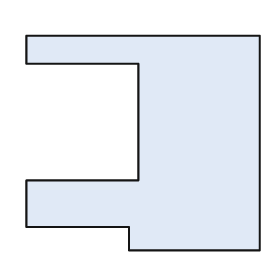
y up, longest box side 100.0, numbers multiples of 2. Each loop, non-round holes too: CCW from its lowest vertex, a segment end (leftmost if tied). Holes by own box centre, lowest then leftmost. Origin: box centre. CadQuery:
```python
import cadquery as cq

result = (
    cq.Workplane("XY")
    .moveTo(-6.0, -46.0)
    .lineTo(50.0, -46.0)
    .lineTo(50.0, 46.0)
    .lineTo(-50.0, 46.0)
    .lineTo(-50.0, 34.0)
    .lineTo(-2.0, 34.0)
    .lineTo(-2.0, -16.0)
    .lineTo(-50.0, -16.0)
    .lineTo(-50.0, -36.0)
    .lineTo(-6.0, -36.0)
    .close()
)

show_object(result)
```